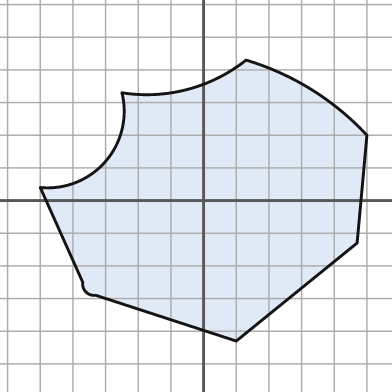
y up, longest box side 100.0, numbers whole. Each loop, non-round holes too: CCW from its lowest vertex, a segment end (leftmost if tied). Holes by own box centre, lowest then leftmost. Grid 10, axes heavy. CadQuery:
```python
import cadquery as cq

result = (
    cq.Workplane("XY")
    .moveTo(10.0, -43.0)
    .lineTo(47.0, -13.0)
    .lineTo(50.0, 20.0)
    .threePointArc((33.0, 34.0), (13.0, 43.0))
    .threePointArc((-5.0, 34.0), (-25.0, 33.0))
    .threePointArc((-30.0, 12.0), (-50.0, 4.0))
    .lineTo(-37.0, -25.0)
    .threePointArc((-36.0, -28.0), (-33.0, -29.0))
    .close()
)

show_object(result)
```